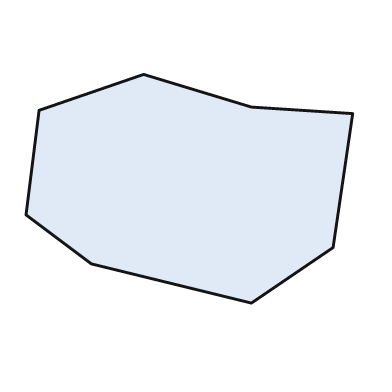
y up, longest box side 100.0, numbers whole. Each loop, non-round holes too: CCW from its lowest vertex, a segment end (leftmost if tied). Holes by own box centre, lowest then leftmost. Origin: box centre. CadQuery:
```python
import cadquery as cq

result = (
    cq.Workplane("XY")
    .moveTo(19.0, -35.0)
    .lineTo(44.0, -18.0)
    .lineTo(50.0, 23.0)
    .lineTo(19.0, 25.0)
    .lineTo(-14.0, 35.0)
    .lineTo(-46.0, 24.0)
    .lineTo(-50.0, -8.0)
    .lineTo(-30.0, -23.0)
    .close()
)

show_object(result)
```